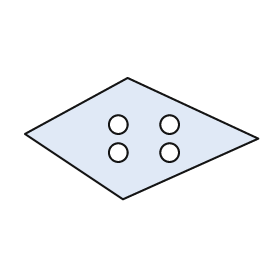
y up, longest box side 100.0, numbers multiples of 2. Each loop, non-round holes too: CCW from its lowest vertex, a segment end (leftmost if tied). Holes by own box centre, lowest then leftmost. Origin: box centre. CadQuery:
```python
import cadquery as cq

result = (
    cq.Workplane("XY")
    .moveTo(-8.0, -26.0)
    .lineTo(50.0, 0.0)
    .lineTo(-6.0, 26.0)
    .lineTo(-50.0, 2.0)
    .close()
    .moveTo(-10.0, -6.0)
    .circle(4.0)
    .moveTo(12.0, -6.0)
    .circle(4.0)
    .moveTo(-10.0, 6.0)
    .circle(4.0)
    .moveTo(12.0, 6.0)
    .circle(4.0)
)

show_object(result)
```